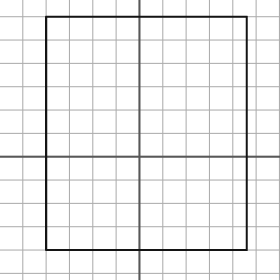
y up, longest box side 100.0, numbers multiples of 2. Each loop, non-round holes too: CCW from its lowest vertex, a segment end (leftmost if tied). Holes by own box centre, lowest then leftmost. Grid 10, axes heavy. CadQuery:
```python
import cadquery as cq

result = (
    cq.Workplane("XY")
    .moveTo(-40.0, -40.0)
    .lineTo(46.0, -40.0)
    .lineTo(46.0, 60.0)
    .lineTo(-40.0, 60.0)
    .close()
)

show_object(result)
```